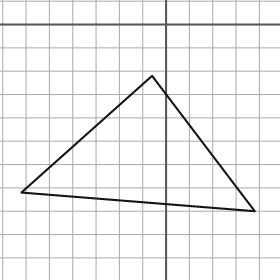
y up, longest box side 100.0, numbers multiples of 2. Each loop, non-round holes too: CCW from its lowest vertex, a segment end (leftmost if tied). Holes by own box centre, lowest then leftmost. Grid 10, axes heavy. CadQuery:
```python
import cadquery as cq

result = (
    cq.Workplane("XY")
    .moveTo(38.0, -80.0)
    .lineTo(-6.0, -22.0)
    .lineTo(-62.0, -72.0)
    .close()
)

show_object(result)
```